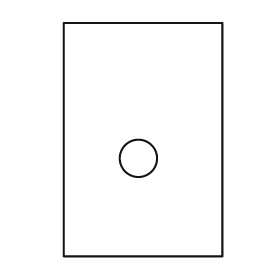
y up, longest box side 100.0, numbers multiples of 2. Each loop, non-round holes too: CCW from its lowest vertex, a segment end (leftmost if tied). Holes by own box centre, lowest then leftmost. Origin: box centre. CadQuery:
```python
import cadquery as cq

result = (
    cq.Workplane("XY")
    .moveTo(-34.0, -50.0)
    .lineTo(34.0, -50.0)
    .lineTo(34.0, 50.0)
    .lineTo(-34.0, 50.0)
    .close()
    .moveTo(-2.0, -8.0)
    .circle(8.0)
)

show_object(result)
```